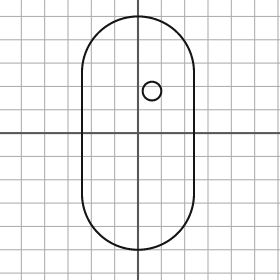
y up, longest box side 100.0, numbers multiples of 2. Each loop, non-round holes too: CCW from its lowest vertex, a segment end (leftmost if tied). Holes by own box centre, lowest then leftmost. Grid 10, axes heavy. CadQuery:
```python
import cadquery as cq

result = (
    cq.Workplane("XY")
    .moveTo(-24.0, -26.0)
    .threePointArc((0.0, -50.0), (24.0, -26.0))
    .lineTo(24.0, 26.0)
    .threePointArc((0.0, 50.0), (-24.0, 26.0))
    .close()
    .moveTo(6.0, 18.0)
    .circle(4.0)
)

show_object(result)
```